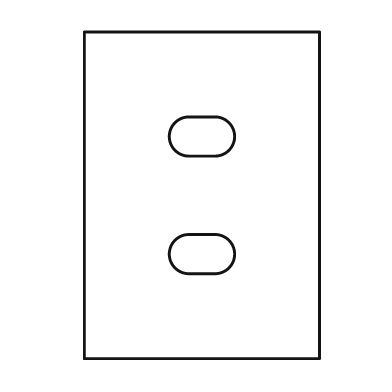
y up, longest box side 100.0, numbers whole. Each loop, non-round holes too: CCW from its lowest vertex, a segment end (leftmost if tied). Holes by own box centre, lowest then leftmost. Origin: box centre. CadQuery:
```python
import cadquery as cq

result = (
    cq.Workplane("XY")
    .moveTo(-36.0, -50.0)
    .lineTo(36.0, -50.0)
    .lineTo(36.0, 50.0)
    .lineTo(-36.0, 50.0)
    .close()
    .moveTo(-4.0, -24.0)
    .lineTo(4.0, -24.0)
    .threePointArc((10.0, -18.0), (4.0, -12.0))
    .lineTo(-4.0, -12.0)
    .threePointArc((-10.0, -18.0), (-4.0, -24.0))
    .close()
    .moveTo(-4.0, 12.0)
    .lineTo(4.0, 12.0)
    .threePointArc((10.0, 18.0), (4.0, 24.0))
    .lineTo(-4.0, 24.0)
    .threePointArc((-10.0, 18.0), (-4.0, 12.0))
    .close()
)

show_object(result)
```